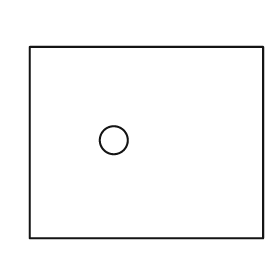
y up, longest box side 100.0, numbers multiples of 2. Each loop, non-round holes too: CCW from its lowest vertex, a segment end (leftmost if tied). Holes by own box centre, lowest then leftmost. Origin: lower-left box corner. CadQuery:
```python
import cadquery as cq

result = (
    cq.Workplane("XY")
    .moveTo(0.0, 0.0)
    .lineTo(100.0, 0.0)
    .lineTo(100.0, 82.0)
    .lineTo(0.0, 82.0)
    .close()
    .moveTo(36.0, 42.0)
    .circle(6.0)
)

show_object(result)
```